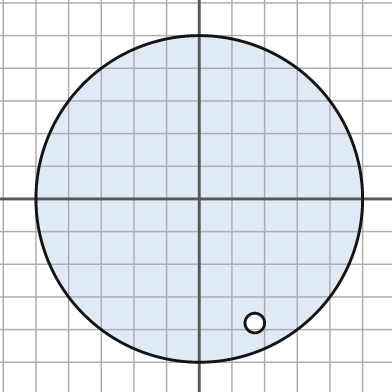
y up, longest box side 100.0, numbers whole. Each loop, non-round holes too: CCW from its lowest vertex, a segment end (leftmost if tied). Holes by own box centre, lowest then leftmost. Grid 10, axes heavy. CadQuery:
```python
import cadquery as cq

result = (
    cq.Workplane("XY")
    .moveTo(0.0, 0.0)
    .circle(50.0)
    .moveTo(17.0, -38.0)
    .circle(3.0)
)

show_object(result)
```